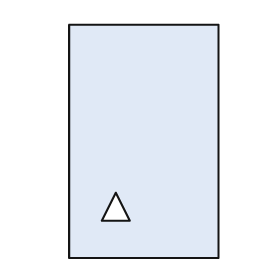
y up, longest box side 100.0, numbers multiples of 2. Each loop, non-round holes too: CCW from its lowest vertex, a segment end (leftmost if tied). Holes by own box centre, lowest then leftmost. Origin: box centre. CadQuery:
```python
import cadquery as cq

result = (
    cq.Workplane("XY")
    .moveTo(-32.0, -50.0)
    .lineTo(32.0, -50.0)
    .lineTo(32.0, 50.0)
    .lineTo(-32.0, 50.0)
    .close()
    .moveTo(-18.0, -34.0)
    .lineTo(-6.0, -34.0)
    .lineTo(-12.0, -22.0)
    .close()
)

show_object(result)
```